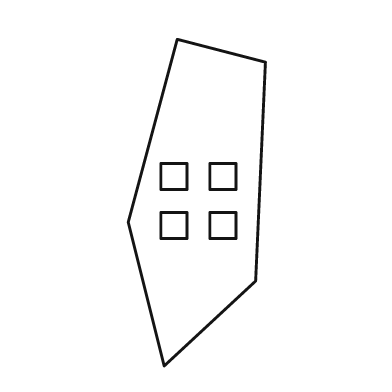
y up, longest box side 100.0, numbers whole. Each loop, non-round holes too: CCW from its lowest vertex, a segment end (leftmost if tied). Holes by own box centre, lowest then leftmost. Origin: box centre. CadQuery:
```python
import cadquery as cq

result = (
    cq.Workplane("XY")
    .moveTo(-10.0, -50.0)
    .lineTo(18.0, -24.0)
    .lineTo(21.0, 43.0)
    .lineTo(-6.0, 50.0)
    .lineTo(-21.0, -6.0)
    .close()
    .moveTo(-11.0, -11.0)
    .lineTo(-3.0, -11.0)
    .lineTo(-3.0, -3.0)
    .lineTo(-11.0, -3.0)
    .close()
    .moveTo(4.0, -11.0)
    .lineTo(12.0, -11.0)
    .lineTo(12.0, -3.0)
    .lineTo(4.0, -3.0)
    .close()
    .moveTo(-11.0, 4.0)
    .lineTo(-3.0, 4.0)
    .lineTo(-3.0, 12.0)
    .lineTo(-11.0, 12.0)
    .close()
    .moveTo(4.0, 4.0)
    .lineTo(12.0, 4.0)
    .lineTo(12.0, 12.0)
    .lineTo(4.0, 12.0)
    .close()
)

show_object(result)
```